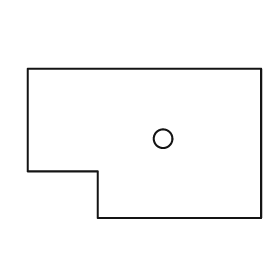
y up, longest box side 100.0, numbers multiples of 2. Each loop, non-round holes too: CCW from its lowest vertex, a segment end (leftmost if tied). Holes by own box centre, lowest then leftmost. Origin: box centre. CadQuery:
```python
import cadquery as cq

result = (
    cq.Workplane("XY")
    .moveTo(-20.0, -32.0)
    .lineTo(50.0, -32.0)
    .lineTo(50.0, 32.0)
    .lineTo(-50.0, 32.0)
    .lineTo(-50.0, -12.0)
    .lineTo(-20.0, -12.0)
    .close()
    .moveTo(8.0, 2.0)
    .circle(4.0)
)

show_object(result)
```